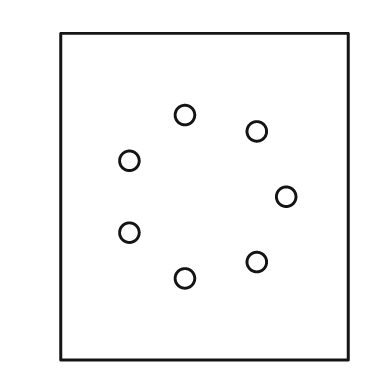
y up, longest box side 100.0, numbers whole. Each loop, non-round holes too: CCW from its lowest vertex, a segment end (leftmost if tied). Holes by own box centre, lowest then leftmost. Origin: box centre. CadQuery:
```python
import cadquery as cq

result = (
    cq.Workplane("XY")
    .moveTo(-44.0, -50.0)
    .lineTo(44.0, -50.0)
    .lineTo(44.0, 50.0)
    .lineTo(-44.0, 50.0)
    .close()
    .moveTo(-6.0, -25.0)
    .circle(3.0)
    .moveTo(16.0, -20.0)
    .circle(3.0)
    .moveTo(-23.0, -11.0)
    .circle(3.0)
    .moveTo(25.0, 0.0)
    .circle(3.0)
    .moveTo(-23.0, 11.0)
    .circle(3.0)
    .moveTo(16.0, 20.0)
    .circle(3.0)
    .moveTo(-6.0, 25.0)
    .circle(3.0)
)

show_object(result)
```